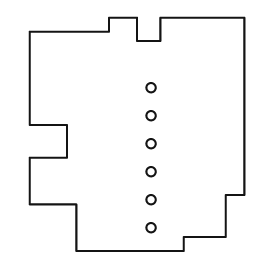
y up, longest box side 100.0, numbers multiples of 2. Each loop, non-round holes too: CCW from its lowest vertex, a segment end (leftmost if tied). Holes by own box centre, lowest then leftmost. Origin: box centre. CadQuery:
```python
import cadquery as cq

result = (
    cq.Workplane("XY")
    .moveTo(-26.0, -50.0)
    .lineTo(20.0, -50.0)
    .lineTo(20.0, -44.0)
    .lineTo(38.0, -44.0)
    .lineTo(38.0, -26.0)
    .lineTo(46.0, -26.0)
    .lineTo(46.0, 50.0)
    .lineTo(10.0, 50.0)
    .lineTo(10.0, 40.0)
    .lineTo(0.0, 40.0)
    .lineTo(0.0, 50.0)
    .lineTo(-12.0, 50.0)
    .lineTo(-12.0, 44.0)
    .lineTo(-46.0, 44.0)
    .lineTo(-46.0, 4.0)
    .lineTo(-30.0, 4.0)
    .lineTo(-30.0, -10.0)
    .lineTo(-46.0, -10.0)
    .lineTo(-46.0, -30.0)
    .lineTo(-26.0, -30.0)
    .close()
    .moveTo(6.0, -40.0)
    .circle(2.0)
    .moveTo(6.0, -28.0)
    .circle(2.0)
    .moveTo(6.0, -16.0)
    .circle(2.0)
    .moveTo(6.0, -4.0)
    .circle(2.0)
    .moveTo(6.0, 8.0)
    .circle(2.0)
    .moveTo(6.0, 20.0)
    .circle(2.0)
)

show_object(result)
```